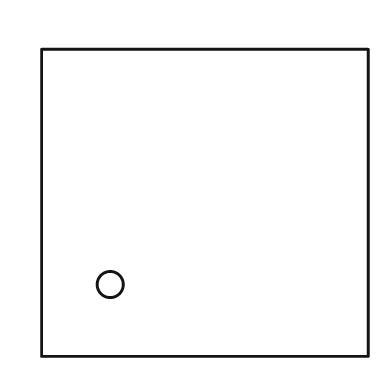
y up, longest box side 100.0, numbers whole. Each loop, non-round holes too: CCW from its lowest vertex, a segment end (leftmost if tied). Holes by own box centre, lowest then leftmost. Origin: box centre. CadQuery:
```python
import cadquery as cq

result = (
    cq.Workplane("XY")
    .moveTo(-50.0, -47.0)
    .lineTo(50.0, -47.0)
    .lineTo(50.0, 47.0)
    .lineTo(-50.0, 47.0)
    .close()
    .moveTo(-29.0, -25.0)
    .circle(4.0)
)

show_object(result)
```